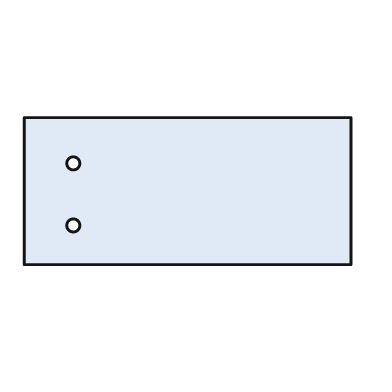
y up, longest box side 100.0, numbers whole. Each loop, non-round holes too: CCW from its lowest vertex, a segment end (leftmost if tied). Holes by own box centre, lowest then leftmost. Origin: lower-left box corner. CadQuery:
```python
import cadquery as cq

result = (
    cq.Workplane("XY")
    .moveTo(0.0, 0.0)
    .lineTo(100.0, 0.0)
    .lineTo(100.0, 45.0)
    .lineTo(0.0, 45.0)
    .close()
    .moveTo(15.0, 12.0)
    .circle(2.0)
    .moveTo(15.0, 31.0)
    .circle(2.0)
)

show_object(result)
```